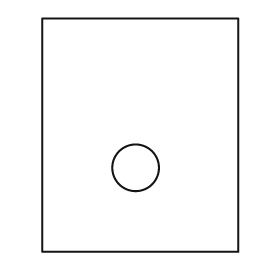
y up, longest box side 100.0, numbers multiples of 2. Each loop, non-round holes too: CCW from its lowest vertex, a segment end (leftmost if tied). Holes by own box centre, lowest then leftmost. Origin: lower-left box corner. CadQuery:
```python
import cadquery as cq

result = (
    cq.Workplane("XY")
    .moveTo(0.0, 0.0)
    .lineTo(84.0, 0.0)
    .lineTo(84.0, 100.0)
    .lineTo(0.0, 100.0)
    .close()
    .moveTo(40.0, 36.0)
    .circle(10.0)
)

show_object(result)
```